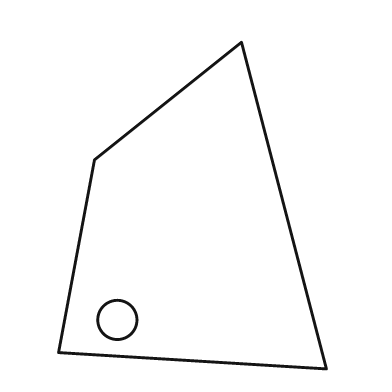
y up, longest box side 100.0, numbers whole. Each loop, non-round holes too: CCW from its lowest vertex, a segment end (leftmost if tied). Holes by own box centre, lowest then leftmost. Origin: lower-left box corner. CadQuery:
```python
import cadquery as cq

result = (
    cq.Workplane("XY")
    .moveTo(82.0, 0.0)
    .lineTo(56.0, 100.0)
    .lineTo(11.0, 64.0)
    .lineTo(0.0, 5.0)
    .close()
    .moveTo(18.0, 15.0)
    .circle(6.0)
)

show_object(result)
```